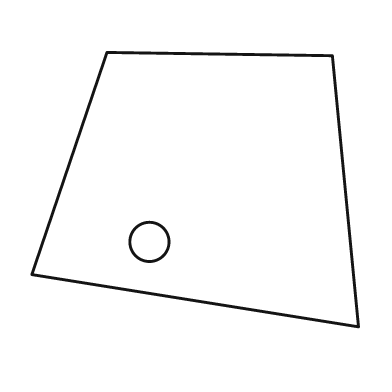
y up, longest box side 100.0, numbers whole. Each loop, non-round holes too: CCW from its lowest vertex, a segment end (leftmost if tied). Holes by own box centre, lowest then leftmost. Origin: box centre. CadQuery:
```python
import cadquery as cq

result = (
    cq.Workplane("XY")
    .moveTo(50.0, -42.0)
    .lineTo(42.0, 41.0)
    .lineTo(-27.0, 42.0)
    .lineTo(-50.0, -26.0)
    .close()
    .moveTo(-14.0, -16.0)
    .circle(6.0)
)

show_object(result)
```